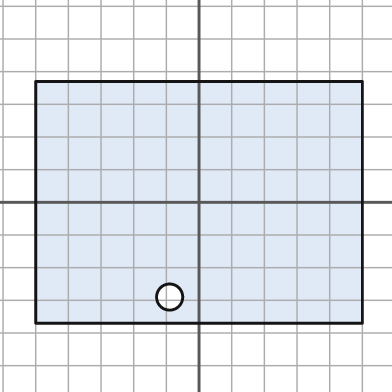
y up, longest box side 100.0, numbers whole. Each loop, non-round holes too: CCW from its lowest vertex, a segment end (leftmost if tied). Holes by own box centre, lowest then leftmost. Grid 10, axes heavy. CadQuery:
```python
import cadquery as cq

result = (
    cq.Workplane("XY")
    .moveTo(-50.0, -37.0)
    .lineTo(50.0, -37.0)
    .lineTo(50.0, 37.0)
    .lineTo(-50.0, 37.0)
    .close()
    .moveTo(-9.0, -29.0)
    .circle(4.0)
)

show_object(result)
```